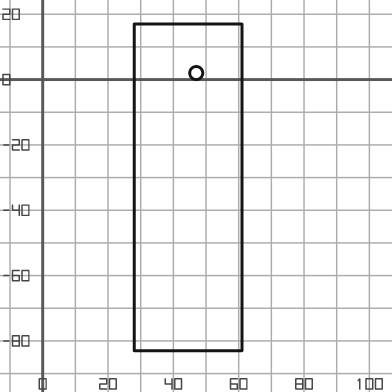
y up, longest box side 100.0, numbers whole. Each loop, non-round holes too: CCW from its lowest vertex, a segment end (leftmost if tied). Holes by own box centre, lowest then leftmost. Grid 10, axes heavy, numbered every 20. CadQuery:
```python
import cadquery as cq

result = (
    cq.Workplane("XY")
    .moveTo(28.0, -83.0)
    .lineTo(61.0, -83.0)
    .lineTo(61.0, 17.0)
    .lineTo(28.0, 17.0)
    .close()
    .moveTo(47.0, 2.0)
    .circle(2.0)
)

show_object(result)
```